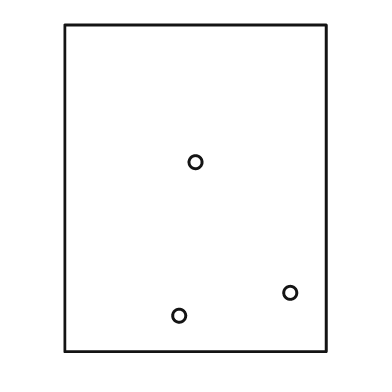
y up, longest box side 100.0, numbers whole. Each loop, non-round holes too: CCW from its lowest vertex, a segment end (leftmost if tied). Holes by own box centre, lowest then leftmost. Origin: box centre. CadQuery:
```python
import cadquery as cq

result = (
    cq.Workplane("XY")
    .moveTo(-40.0, -50.0)
    .lineTo(40.0, -50.0)
    .lineTo(40.0, 50.0)
    .lineTo(-40.0, 50.0)
    .close()
    .moveTo(-5.0, -39.0)
    .circle(2.0)
    .moveTo(29.0, -32.0)
    .circle(2.0)
    .moveTo(0.0, 8.0)
    .circle(2.0)
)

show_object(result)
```